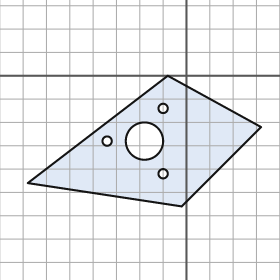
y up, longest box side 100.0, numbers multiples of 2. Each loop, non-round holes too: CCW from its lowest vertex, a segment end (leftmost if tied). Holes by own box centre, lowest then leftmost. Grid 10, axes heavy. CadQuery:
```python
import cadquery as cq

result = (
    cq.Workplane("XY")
    .moveTo(-2.0, -56.0)
    .lineTo(32.0, -22.0)
    .lineTo(-8.0, 0.0)
    .lineTo(-68.0, -46.0)
    .close()
    .moveTo(-10.0, -42.0)
    .circle(2.0)
    .moveTo(-34.0, -28.0)
    .circle(2.0)
    .moveTo(-18.0, -28.0)
    .circle(8.0)
    .moveTo(-10.0, -14.0)
    .circle(2.0)
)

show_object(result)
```